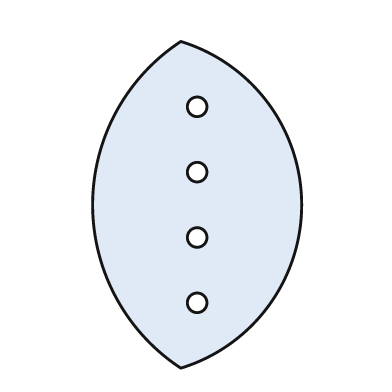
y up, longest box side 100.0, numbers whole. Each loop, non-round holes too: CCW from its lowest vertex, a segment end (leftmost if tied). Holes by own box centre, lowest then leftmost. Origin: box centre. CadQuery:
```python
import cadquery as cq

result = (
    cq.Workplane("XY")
    .moveTo(-5.0, -50.0)
    .threePointArc((32.0, 0.0), (-5.0, 50.0))
    .threePointArc((-32.0, 0.0), (-5.0, -50.0))
    .close()
    .moveTo(0.0, -30.0)
    .circle(3.0)
    .moveTo(0.0, -10.0)
    .circle(3.0)
    .moveTo(0.0, 10.0)
    .circle(3.0)
    .moveTo(0.0, 30.0)
    .circle(3.0)
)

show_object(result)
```